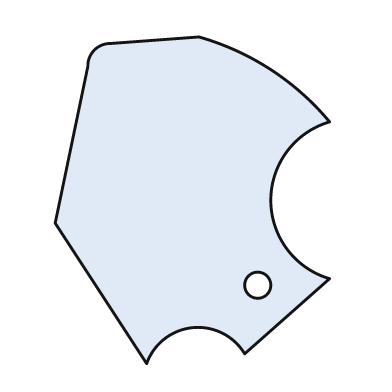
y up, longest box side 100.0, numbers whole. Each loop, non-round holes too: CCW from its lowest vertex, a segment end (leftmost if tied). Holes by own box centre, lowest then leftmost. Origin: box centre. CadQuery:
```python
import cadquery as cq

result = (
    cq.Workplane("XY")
    .moveTo(-14.0, -50.0)
    .threePointArc((0.0, -39.0), (16.0, -47.0))
    .lineTo(42.0, -24.0)
    .threePointArc((24.0, 0.0), (42.0, 24.0))
    .threePointArc((24.0, 40.0), (2.0, 50.0))
    .lineTo(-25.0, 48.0)
    .threePointArc((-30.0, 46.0), (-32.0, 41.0))
    .lineTo(-42.0, -7.0)
    .close()
    .moveTo(20.0, -26.0)
    .circle(4.0)
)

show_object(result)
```